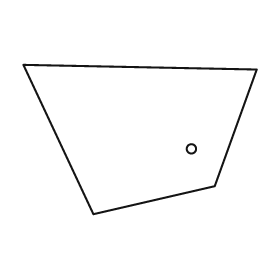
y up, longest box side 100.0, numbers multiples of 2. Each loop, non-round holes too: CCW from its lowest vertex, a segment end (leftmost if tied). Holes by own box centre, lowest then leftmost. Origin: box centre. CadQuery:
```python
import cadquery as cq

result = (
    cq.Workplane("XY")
    .moveTo(-20.0, -32.0)
    .lineTo(32.0, -20.0)
    .lineTo(50.0, 30.0)
    .lineTo(-50.0, 32.0)
    .close()
    .moveTo(22.0, -4.0)
    .circle(2.0)
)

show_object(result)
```